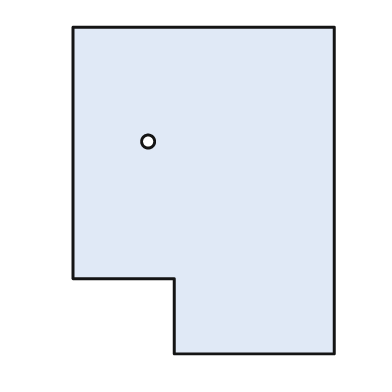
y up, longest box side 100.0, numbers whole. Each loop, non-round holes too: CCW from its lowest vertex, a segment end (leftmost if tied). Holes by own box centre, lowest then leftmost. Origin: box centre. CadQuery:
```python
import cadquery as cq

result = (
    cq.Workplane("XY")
    .moveTo(-9.0, -50.0)
    .lineTo(40.0, -50.0)
    .lineTo(40.0, 50.0)
    .lineTo(-40.0, 50.0)
    .lineTo(-40.0, -27.0)
    .lineTo(-9.0, -27.0)
    .close()
    .moveTo(-17.0, 15.0)
    .circle(2.0)
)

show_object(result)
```